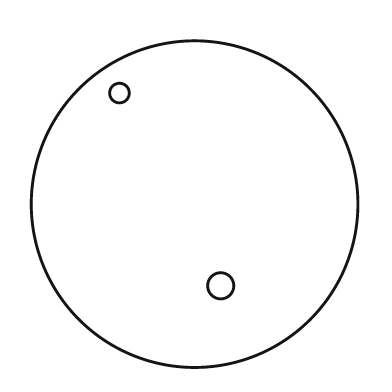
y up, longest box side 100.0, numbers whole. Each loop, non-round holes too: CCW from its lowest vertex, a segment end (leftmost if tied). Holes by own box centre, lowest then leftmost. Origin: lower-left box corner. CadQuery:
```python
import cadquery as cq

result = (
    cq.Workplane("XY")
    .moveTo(50.0, 50.0)
    .circle(50.0)
    .moveTo(58.0, 25.0)
    .circle(4.0)
    .moveTo(27.0, 84.0)
    .circle(3.0)
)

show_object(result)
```